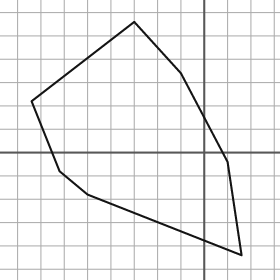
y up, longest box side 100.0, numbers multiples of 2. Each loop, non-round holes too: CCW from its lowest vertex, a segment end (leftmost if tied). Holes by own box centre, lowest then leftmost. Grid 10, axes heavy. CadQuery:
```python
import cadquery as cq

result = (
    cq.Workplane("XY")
    .moveTo(16.0, -44.0)
    .lineTo(10.0, -4.0)
    .lineTo(-10.0, 34.0)
    .lineTo(-30.0, 56.0)
    .lineTo(-74.0, 22.0)
    .lineTo(-62.0, -8.0)
    .lineTo(-50.0, -18.0)
    .close()
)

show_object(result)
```